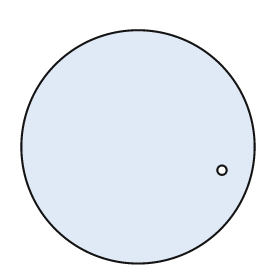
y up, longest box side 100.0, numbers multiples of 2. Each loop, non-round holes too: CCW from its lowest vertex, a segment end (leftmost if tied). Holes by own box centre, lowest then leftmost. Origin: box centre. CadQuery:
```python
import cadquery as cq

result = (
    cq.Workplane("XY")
    .moveTo(0.0, 0.0)
    .circle(50.0)
    .moveTo(36.0, -10.0)
    .circle(2.0)
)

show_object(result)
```